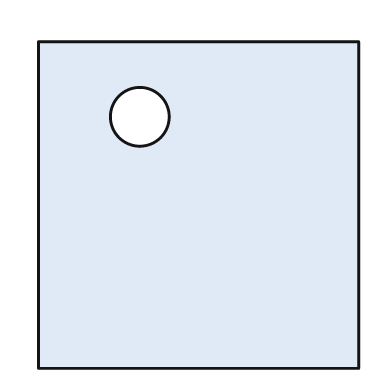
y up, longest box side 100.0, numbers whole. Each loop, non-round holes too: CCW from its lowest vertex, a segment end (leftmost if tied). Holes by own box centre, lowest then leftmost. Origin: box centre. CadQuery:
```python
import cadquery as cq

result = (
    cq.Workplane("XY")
    .moveTo(-49.0, -50.0)
    .lineTo(49.0, -50.0)
    .lineTo(49.0, 50.0)
    .lineTo(-49.0, 50.0)
    .close()
    .moveTo(-18.0, 27.0)
    .circle(9.0)
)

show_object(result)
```